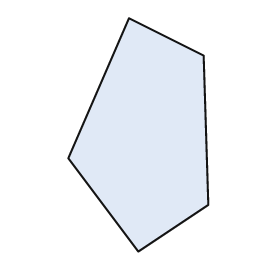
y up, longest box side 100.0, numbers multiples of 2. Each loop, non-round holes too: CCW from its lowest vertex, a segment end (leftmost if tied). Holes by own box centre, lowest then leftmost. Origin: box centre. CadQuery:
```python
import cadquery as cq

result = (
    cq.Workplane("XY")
    .moveTo(0.0, -50.0)
    .lineTo(30.0, -30.0)
    .lineTo(28.0, 34.0)
    .lineTo(-4.0, 50.0)
    .lineTo(-30.0, -10.0)
    .close()
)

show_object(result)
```